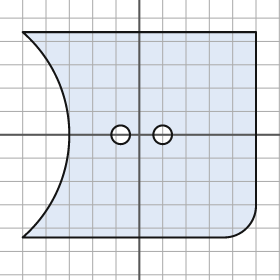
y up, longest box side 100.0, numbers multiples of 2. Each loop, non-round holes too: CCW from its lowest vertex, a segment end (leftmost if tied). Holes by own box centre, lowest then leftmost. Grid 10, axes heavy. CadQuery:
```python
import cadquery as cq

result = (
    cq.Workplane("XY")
    .moveTo(-50.0, -44.0)
    .lineTo(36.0, -44.0)
    .threePointArc((46.0, -40.0), (50.0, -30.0))
    .lineTo(50.0, 44.0)
    .lineTo(-50.0, 44.0)
    .threePointArc((-30.0, 0.0), (-50.0, -44.0))
    .close()
    .moveTo(-8.0, 0.0)
    .circle(4.0)
    .moveTo(10.0, 0.0)
    .circle(4.0)
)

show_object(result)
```